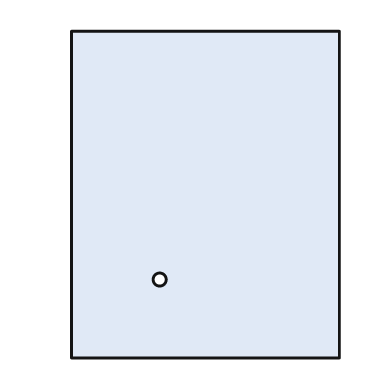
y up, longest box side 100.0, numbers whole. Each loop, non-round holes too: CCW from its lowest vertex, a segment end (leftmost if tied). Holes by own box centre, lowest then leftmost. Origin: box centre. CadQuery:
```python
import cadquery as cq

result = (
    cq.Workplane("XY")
    .moveTo(-41.0, -50.0)
    .lineTo(41.0, -50.0)
    .lineTo(41.0, 50.0)
    .lineTo(-41.0, 50.0)
    .close()
    .moveTo(-14.0, -26.0)
    .circle(2.0)
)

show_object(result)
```